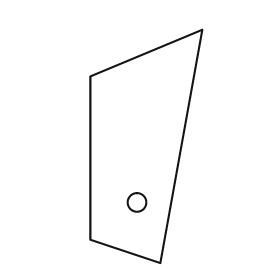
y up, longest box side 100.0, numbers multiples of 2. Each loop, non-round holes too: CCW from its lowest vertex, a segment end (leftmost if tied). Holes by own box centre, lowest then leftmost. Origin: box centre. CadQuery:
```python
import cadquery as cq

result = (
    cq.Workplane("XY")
    .moveTo(6.0, -50.0)
    .lineTo(24.0, 50.0)
    .lineTo(-24.0, 30.0)
    .lineTo(-24.0, -40.0)
    .close()
    .moveTo(-4.0, -24.0)
    .circle(4.0)
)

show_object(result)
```